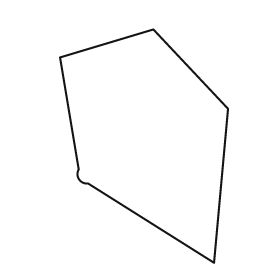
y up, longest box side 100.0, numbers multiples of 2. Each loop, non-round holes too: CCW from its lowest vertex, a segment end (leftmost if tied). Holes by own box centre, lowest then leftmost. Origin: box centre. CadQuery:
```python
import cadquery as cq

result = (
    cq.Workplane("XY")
    .moveTo(30.0, -50.0)
    .lineTo(36.0, 16.0)
    .lineTo(4.0, 50.0)
    .lineTo(-36.0, 38.0)
    .lineTo(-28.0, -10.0)
    .threePointArc((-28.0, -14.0), (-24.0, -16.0))
    .close()
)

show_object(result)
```